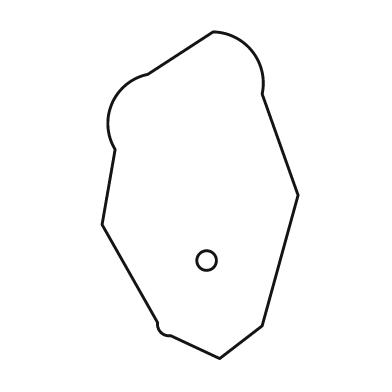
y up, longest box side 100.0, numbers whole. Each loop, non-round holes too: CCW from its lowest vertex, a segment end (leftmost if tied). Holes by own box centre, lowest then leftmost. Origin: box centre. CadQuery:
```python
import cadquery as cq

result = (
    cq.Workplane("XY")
    .moveTo(6.0, -50.0)
    .lineTo(19.0, -40.0)
    .lineTo(30.0, 0.0)
    .lineTo(19.0, 31.0)
    .threePointArc((16.0, 44.0), (4.0, 50.0))
    .lineTo(-16.0, 37.0)
    .threePointArc((-27.0, 28.0), (-26.0, 14.0))
    .lineTo(-30.0, -9.0)
    .lineTo(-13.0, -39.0)
    .threePointArc((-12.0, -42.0), (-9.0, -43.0))
    .close()
    .moveTo(2.0, -20.0)
    .circle(3.0)
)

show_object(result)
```